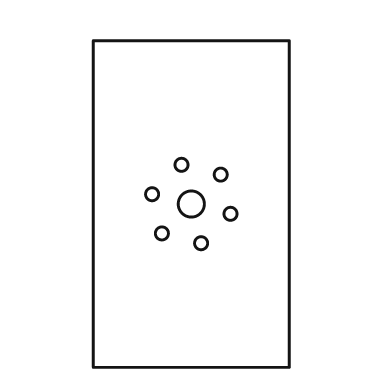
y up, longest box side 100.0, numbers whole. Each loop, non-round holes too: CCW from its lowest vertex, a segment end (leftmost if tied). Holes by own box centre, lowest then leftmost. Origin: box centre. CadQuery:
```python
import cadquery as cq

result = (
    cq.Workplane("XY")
    .moveTo(-30.0, -50.0)
    .lineTo(30.0, -50.0)
    .lineTo(30.0, 50.0)
    .lineTo(-30.0, 50.0)
    .close()
    .moveTo(3.0, -12.0)
    .circle(2.0)
    .moveTo(-9.0, -9.0)
    .circle(2.0)
    .moveTo(12.0, -3.0)
    .circle(2.0)
    .moveTo(0.0, 0.0)
    .circle(4.0)
    .moveTo(-12.0, 3.0)
    .circle(2.0)
    .moveTo(9.0, 9.0)
    .circle(2.0)
    .moveTo(-3.0, 12.0)
    .circle(2.0)
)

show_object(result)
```